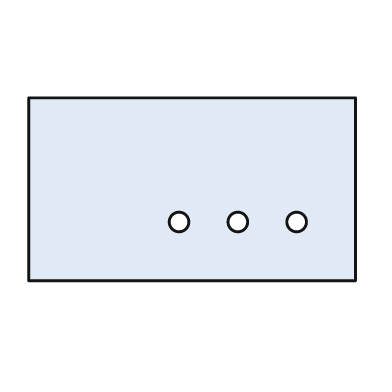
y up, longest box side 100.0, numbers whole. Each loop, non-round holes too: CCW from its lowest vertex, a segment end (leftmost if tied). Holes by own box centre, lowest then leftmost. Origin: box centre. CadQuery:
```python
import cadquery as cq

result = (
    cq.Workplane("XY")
    .moveTo(-50.0, -28.0)
    .lineTo(50.0, -28.0)
    .lineTo(50.0, 28.0)
    .lineTo(-50.0, 28.0)
    .close()
    .moveTo(-4.0, -10.0)
    .circle(3.0)
    .moveTo(14.0, -10.0)
    .circle(3.0)
    .moveTo(32.0, -10.0)
    .circle(3.0)
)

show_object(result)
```